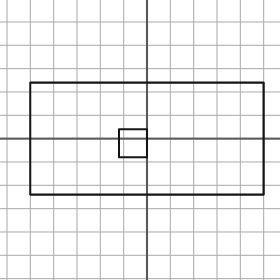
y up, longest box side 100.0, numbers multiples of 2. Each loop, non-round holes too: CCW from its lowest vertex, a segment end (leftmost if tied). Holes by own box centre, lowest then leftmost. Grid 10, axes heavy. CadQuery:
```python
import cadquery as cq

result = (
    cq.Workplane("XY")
    .moveTo(-50.0, -24.0)
    .lineTo(50.0, -24.0)
    .lineTo(50.0, 24.0)
    .lineTo(-50.0, 24.0)
    .close()
    .moveTo(-12.0, -8.0)
    .lineTo(0.0, -8.0)
    .lineTo(0.0, 4.0)
    .lineTo(-12.0, 4.0)
    .close()
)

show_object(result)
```